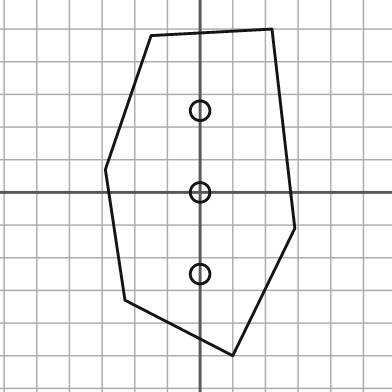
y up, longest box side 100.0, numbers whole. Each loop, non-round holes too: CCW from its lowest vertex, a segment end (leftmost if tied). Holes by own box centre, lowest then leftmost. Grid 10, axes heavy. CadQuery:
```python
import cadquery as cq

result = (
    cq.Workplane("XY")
    .moveTo(10.0, -50.0)
    .lineTo(29.0, -11.0)
    .lineTo(22.0, 50.0)
    .lineTo(-15.0, 48.0)
    .lineTo(-29.0, 7.0)
    .lineTo(-23.0, -33.0)
    .close()
    .moveTo(0.0, -25.0)
    .circle(3.0)
    .moveTo(0.0, 0.0)
    .circle(3.0)
    .moveTo(0.0, 25.0)
    .circle(3.0)
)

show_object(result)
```